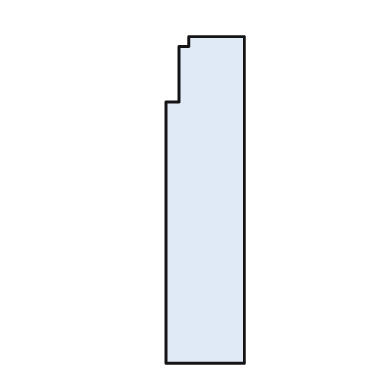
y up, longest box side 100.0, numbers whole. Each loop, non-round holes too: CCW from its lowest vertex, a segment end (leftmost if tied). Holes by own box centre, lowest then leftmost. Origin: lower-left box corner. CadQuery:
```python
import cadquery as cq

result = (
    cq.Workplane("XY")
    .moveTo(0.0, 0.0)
    .lineTo(24.0, 0.0)
    .lineTo(24.0, 100.0)
    .lineTo(7.0, 100.0)
    .lineTo(7.0, 97.0)
    .lineTo(4.0, 97.0)
    .lineTo(4.0, 80.0)
    .lineTo(0.0, 80.0)
    .close()
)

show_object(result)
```